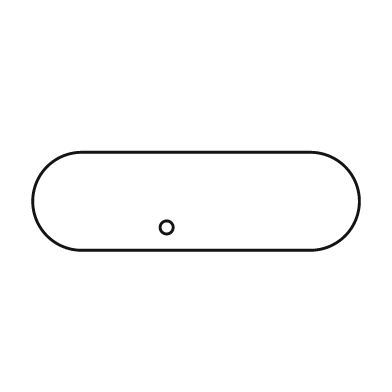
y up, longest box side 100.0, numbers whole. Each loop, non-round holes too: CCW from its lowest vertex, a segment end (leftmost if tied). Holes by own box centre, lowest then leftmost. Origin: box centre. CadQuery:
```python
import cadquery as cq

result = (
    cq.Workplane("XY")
    .moveTo(-35.0, -15.0)
    .lineTo(35.0, -15.0)
    .threePointArc((50.0, 0.0), (35.0, 15.0))
    .lineTo(-35.0, 15.0)
    .threePointArc((-50.0, 0.0), (-35.0, -15.0))
    .close()
    .moveTo(-9.0, -8.0)
    .circle(2.0)
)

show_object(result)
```